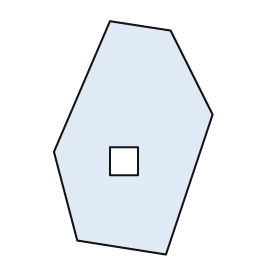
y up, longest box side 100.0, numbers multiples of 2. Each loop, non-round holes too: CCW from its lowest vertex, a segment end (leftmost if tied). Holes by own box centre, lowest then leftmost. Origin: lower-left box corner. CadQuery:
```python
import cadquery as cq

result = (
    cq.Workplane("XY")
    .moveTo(48.0, 0.0)
    .lineTo(68.0, 60.0)
    .lineTo(50.0, 96.0)
    .lineTo(24.0, 100.0)
    .lineTo(0.0, 44.0)
    .lineTo(10.0, 6.0)
    .close()
    .moveTo(24.0, 34.0)
    .lineTo(36.0, 34.0)
    .lineTo(36.0, 46.0)
    .lineTo(24.0, 46.0)
    .close()
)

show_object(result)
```